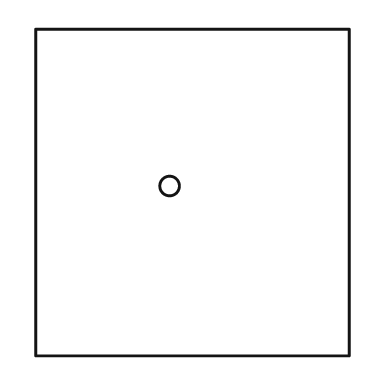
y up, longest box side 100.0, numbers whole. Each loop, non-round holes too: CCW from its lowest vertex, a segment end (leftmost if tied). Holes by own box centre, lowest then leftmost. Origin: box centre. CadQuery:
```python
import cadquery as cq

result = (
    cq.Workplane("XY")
    .moveTo(-48.0, -50.0)
    .lineTo(48.0, -50.0)
    .lineTo(48.0, 50.0)
    .lineTo(-48.0, 50.0)
    .close()
    .moveTo(-7.0, 2.0)
    .circle(3.0)
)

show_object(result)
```